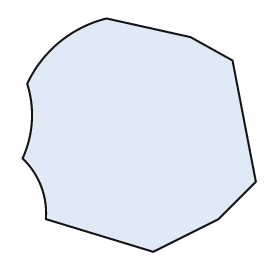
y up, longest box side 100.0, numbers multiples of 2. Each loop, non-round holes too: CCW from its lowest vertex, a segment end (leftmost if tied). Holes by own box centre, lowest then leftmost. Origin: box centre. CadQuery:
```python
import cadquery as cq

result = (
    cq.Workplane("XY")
    .moveTo(6.0, -50.0)
    .lineTo(34.0, -36.0)
    .lineTo(50.0, -20.0)
    .lineTo(40.0, 32.0)
    .lineTo(22.0, 42.0)
    .lineTo(-14.0, 50.0)
    .threePointArc((-34.0, 40.0), (-48.0, 22.0))
    .threePointArc((-46.0, 6.0), (-50.0, -10.0))
    .threePointArc((-42.0, -22.0), (-40.0, -36.0))
    .close()
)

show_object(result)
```